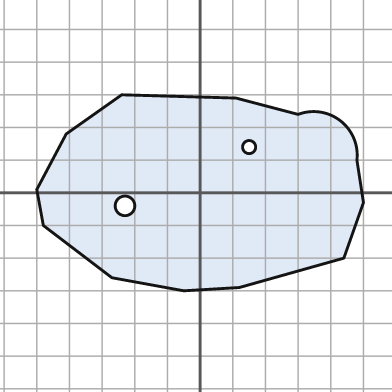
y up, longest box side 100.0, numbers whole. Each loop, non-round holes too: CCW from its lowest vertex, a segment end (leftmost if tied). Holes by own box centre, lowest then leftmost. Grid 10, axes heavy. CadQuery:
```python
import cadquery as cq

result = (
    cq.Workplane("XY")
    .moveTo(-5.0, -30.0)
    .lineTo(12.0, -29.0)
    .lineTo(44.0, -20.0)
    .lineTo(50.0, -3.0)
    .lineTo(48.0, 10.0)
    .threePointArc((43.0, 22.0), (30.0, 24.0))
    .lineTo(11.0, 29.0)
    .lineTo(-24.0, 30.0)
    .lineTo(-41.0, 18.0)
    .lineTo(-50.0, 1.0)
    .lineTo(-48.0, -10.0)
    .lineTo(-27.0, -26.0)
    .close()
    .moveTo(-23.0, -4.0)
    .circle(3.0)
    .moveTo(15.0, 14.0)
    .circle(2.0)
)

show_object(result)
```